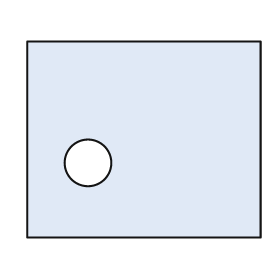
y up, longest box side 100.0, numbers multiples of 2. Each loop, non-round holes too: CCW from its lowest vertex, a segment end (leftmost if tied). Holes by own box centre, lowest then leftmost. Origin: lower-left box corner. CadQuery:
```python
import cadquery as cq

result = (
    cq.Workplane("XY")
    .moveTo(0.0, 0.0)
    .lineTo(100.0, 0.0)
    .lineTo(100.0, 84.0)
    .lineTo(0.0, 84.0)
    .close()
    .moveTo(26.0, 32.0)
    .circle(10.0)
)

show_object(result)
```